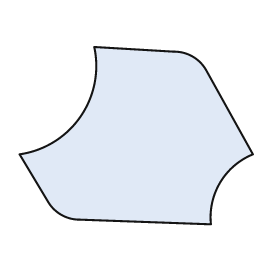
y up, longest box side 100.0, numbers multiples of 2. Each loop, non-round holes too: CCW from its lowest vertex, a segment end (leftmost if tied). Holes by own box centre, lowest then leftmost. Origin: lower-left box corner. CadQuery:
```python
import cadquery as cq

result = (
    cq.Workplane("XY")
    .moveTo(82.0, 0.0)
    .threePointArc((86.0, 18.0), (100.0, 30.0))
    .lineTo(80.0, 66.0)
    .threePointArc((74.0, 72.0), (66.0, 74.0))
    .lineTo(32.0, 76.0)
    .threePointArc((26.0, 46.0), (0.0, 30.0))
    .lineTo(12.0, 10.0)
    .threePointArc((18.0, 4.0), (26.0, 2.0))
    .close()
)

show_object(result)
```